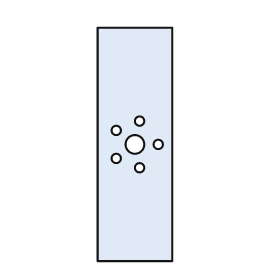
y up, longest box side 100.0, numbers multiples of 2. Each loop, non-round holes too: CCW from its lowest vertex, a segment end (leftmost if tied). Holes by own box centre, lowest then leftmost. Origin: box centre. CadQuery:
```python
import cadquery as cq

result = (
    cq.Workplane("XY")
    .moveTo(-16.0, -50.0)
    .lineTo(16.0, -50.0)
    .lineTo(16.0, 50.0)
    .lineTo(-16.0, 50.0)
    .close()
    .moveTo(2.0, -10.0)
    .circle(2.0)
    .moveTo(-8.0, -6.0)
    .circle(2.0)
    .moveTo(0.0, 0.0)
    .circle(4.0)
    .moveTo(10.0, 0.0)
    .circle(2.0)
    .moveTo(-8.0, 6.0)
    .circle(2.0)
    .moveTo(2.0, 10.0)
    .circle(2.0)
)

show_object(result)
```